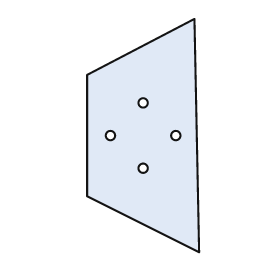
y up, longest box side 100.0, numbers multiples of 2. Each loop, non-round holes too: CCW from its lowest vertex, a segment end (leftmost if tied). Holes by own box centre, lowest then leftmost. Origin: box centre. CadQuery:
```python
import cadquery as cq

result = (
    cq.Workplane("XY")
    .moveTo(24.0, -50.0)
    .lineTo(22.0, 50.0)
    .lineTo(-24.0, 26.0)
    .lineTo(-24.0, -26.0)
    .close()
    .moveTo(0.0, -14.0)
    .circle(2.0)
    .moveTo(-14.0, 0.0)
    .circle(2.0)
    .moveTo(14.0, 0.0)
    .circle(2.0)
    .moveTo(0.0, 14.0)
    .circle(2.0)
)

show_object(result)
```